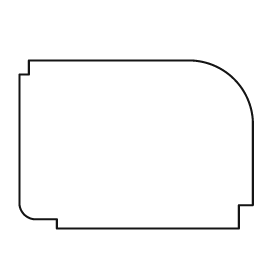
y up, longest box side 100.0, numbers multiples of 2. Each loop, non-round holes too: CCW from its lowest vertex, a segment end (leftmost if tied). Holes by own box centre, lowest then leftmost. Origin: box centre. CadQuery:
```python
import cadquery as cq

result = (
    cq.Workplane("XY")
    .moveTo(-34.0, -36.0)
    .lineTo(44.0, -36.0)
    .lineTo(44.0, -26.0)
    .lineTo(50.0, -26.0)
    .lineTo(50.0, 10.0)
    .threePointArc((42.0, 28.0), (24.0, 36.0))
    .lineTo(-46.0, 36.0)
    .lineTo(-46.0, 30.0)
    .lineTo(-50.0, 30.0)
    .lineTo(-50.0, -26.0)
    .threePointArc((-48.0, -30.0), (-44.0, -32.0))
    .lineTo(-34.0, -32.0)
    .close()
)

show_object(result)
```